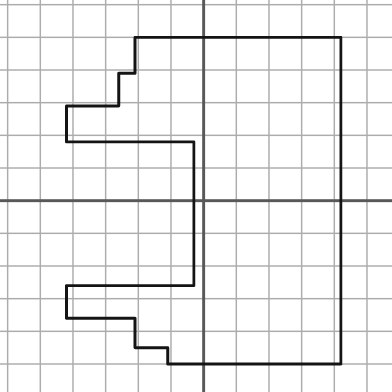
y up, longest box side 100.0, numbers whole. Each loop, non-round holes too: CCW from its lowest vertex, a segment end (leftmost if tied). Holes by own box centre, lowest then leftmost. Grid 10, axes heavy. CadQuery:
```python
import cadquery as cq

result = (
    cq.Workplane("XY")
    .moveTo(-11.0, -50.0)
    .lineTo(42.0, -50.0)
    .lineTo(42.0, 50.0)
    .lineTo(-21.0, 50.0)
    .lineTo(-21.0, 39.0)
    .lineTo(-26.0, 39.0)
    .lineTo(-26.0, 29.0)
    .lineTo(-42.0, 29.0)
    .lineTo(-42.0, 18.0)
    .lineTo(-3.0, 18.0)
    .lineTo(-3.0, -26.0)
    .lineTo(-42.0, -26.0)
    .lineTo(-42.0, -36.0)
    .lineTo(-21.0, -36.0)
    .lineTo(-21.0, -45.0)
    .lineTo(-11.0, -45.0)
    .close()
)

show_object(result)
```